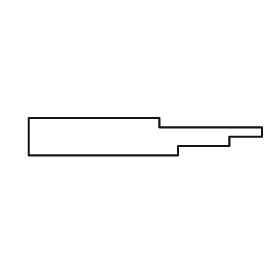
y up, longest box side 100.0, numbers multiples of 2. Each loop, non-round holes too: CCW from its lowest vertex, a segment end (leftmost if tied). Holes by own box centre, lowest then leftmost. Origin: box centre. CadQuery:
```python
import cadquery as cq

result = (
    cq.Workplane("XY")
    .moveTo(-50.0, -8.0)
    .lineTo(14.0, -8.0)
    .lineTo(14.0, -4.0)
    .lineTo(36.0, -4.0)
    .lineTo(36.0, 0.0)
    .lineTo(50.0, 0.0)
    .lineTo(50.0, 4.0)
    .lineTo(6.0, 4.0)
    .lineTo(6.0, 8.0)
    .lineTo(-50.0, 8.0)
    .close()
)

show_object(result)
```